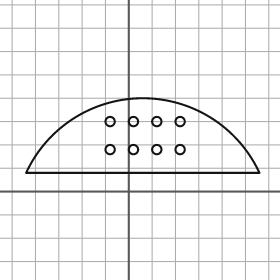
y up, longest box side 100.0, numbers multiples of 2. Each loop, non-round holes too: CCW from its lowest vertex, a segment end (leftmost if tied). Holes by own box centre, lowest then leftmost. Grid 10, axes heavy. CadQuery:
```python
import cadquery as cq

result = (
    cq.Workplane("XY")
    .moveTo(-44.0, 8.0)
    .lineTo(56.0, 8.0)
    .threePointArc((6.0, 40.0), (-44.0, 8.0))
    .close()
    .moveTo(-8.0, 18.0)
    .circle(2.0)
    .moveTo(2.0, 18.0)
    .circle(2.0)
    .moveTo(12.0, 18.0)
    .circle(2.0)
    .moveTo(22.0, 18.0)
    .circle(2.0)
    .moveTo(-8.0, 30.0)
    .circle(2.0)
    .moveTo(2.0, 30.0)
    .circle(2.0)
    .moveTo(12.0, 30.0)
    .circle(2.0)
    .moveTo(22.0, 30.0)
    .circle(2.0)
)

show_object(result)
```